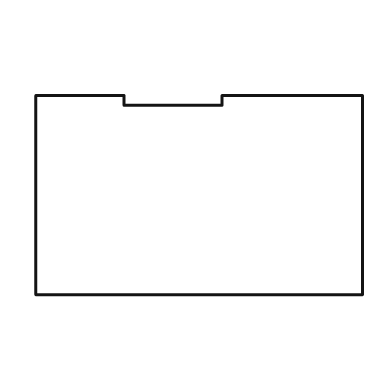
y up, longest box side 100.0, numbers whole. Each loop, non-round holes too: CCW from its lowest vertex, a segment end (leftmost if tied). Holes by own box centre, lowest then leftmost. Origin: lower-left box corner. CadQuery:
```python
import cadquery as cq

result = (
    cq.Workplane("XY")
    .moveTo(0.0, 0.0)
    .lineTo(100.0, 0.0)
    .lineTo(100.0, 61.0)
    .lineTo(57.0, 61.0)
    .lineTo(57.0, 58.0)
    .lineTo(27.0, 58.0)
    .lineTo(27.0, 61.0)
    .lineTo(0.0, 61.0)
    .close()
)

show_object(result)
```